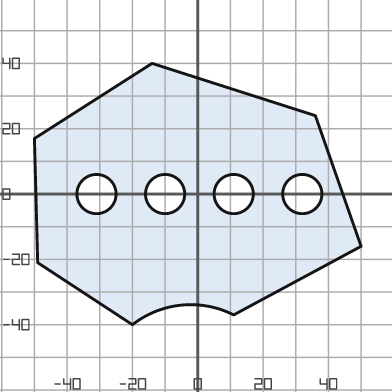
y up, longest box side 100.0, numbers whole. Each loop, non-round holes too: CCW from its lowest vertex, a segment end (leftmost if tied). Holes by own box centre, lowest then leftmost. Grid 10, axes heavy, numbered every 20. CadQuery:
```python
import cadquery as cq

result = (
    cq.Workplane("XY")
    .moveTo(-20.0, -40.0)
    .threePointArc((-5.0, -34.0), (11.0, -37.0))
    .lineTo(50.0, -16.0)
    .lineTo(36.0, 24.0)
    .lineTo(-14.0, 40.0)
    .lineTo(-50.0, 17.0)
    .lineTo(-49.0, -21.0)
    .close()
    .moveTo(-31.0, 0.0)
    .circle(6.0)
    .moveTo(-10.0, 0.0)
    .circle(6.0)
    .moveTo(11.0, 0.0)
    .circle(6.0)
    .moveTo(32.0, 0.0)
    .circle(6.0)
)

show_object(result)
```